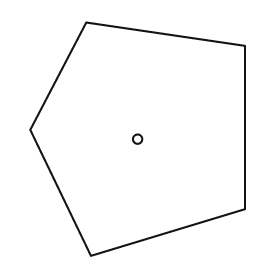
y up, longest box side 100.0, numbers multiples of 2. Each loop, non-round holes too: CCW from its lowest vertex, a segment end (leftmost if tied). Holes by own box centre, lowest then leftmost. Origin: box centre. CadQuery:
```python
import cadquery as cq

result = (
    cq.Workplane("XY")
    .moveTo(-20.0, -50.0)
    .lineTo(46.0, -30.0)
    .lineTo(46.0, 40.0)
    .lineTo(-22.0, 50.0)
    .lineTo(-46.0, 4.0)
    .close()
    .moveTo(0.0, 0.0)
    .circle(2.0)
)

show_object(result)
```